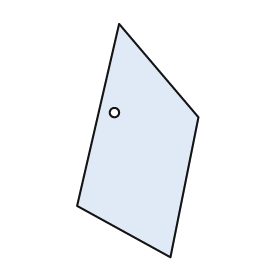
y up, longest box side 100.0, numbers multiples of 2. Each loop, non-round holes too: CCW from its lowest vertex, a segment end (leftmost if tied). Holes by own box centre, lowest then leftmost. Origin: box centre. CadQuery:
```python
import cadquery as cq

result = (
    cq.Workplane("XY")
    .moveTo(14.0, -50.0)
    .lineTo(26.0, 10.0)
    .lineTo(-8.0, 50.0)
    .lineTo(-26.0, -28.0)
    .close()
    .moveTo(-10.0, 12.0)
    .circle(2.0)
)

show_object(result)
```